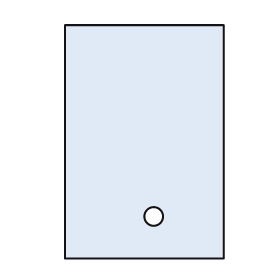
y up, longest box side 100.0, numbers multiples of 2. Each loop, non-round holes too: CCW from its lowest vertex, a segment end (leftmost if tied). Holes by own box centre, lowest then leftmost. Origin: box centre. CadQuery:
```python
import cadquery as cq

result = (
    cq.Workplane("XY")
    .moveTo(-34.0, -50.0)
    .lineTo(34.0, -50.0)
    .lineTo(34.0, 50.0)
    .lineTo(-34.0, 50.0)
    .close()
    .moveTo(4.0, -32.0)
    .circle(4.0)
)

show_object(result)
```